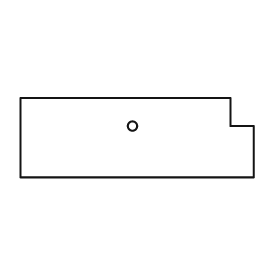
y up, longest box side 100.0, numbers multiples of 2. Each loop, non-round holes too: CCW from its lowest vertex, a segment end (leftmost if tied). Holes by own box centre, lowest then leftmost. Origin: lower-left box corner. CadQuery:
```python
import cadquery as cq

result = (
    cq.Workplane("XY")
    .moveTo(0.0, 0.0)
    .lineTo(100.0, 0.0)
    .lineTo(100.0, 22.0)
    .lineTo(90.0, 22.0)
    .lineTo(90.0, 34.0)
    .lineTo(0.0, 34.0)
    .close()
    .moveTo(48.0, 22.0)
    .circle(2.0)
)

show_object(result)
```